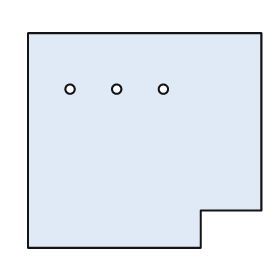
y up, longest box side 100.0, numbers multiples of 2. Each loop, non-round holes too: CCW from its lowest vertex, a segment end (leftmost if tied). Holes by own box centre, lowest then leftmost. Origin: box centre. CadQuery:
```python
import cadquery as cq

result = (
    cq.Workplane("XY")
    .moveTo(-50.0, -46.0)
    .lineTo(24.0, -46.0)
    .lineTo(24.0, -30.0)
    .lineTo(50.0, -30.0)
    .lineTo(50.0, 46.0)
    .lineTo(-50.0, 46.0)
    .close()
    .moveTo(-32.0, 22.0)
    .circle(2.0)
    .moveTo(-12.0, 22.0)
    .circle(2.0)
    .moveTo(8.0, 22.0)
    .circle(2.0)
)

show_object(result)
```